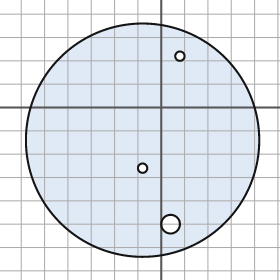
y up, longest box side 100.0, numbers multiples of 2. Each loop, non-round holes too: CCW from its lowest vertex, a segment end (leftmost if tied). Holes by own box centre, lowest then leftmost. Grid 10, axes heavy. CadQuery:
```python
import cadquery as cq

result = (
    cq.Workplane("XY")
    .moveTo(-8.0, -14.0)
    .circle(50.0)
    .moveTo(4.0, -50.0)
    .circle(4.0)
    .moveTo(-8.0, -26.0)
    .circle(2.0)
    .moveTo(8.0, 22.0)
    .circle(2.0)
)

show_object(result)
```